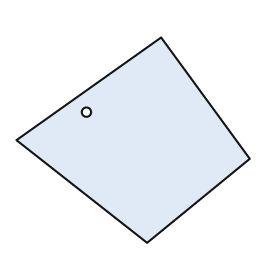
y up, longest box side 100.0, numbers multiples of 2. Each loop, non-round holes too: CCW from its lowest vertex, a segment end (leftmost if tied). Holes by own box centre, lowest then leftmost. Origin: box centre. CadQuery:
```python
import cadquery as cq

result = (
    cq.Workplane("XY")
    .moveTo(6.0, -44.0)
    .lineTo(50.0, -8.0)
    .lineTo(12.0, 44.0)
    .lineTo(-50.0, 0.0)
    .close()
    .moveTo(-20.0, 12.0)
    .circle(2.0)
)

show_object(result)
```